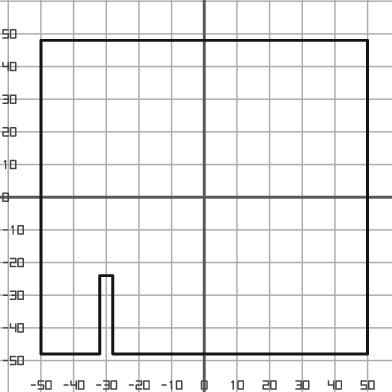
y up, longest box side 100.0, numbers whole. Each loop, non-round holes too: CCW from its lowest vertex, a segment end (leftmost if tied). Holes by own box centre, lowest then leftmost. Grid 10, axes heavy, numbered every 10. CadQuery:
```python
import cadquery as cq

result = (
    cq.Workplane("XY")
    .moveTo(-50.0, -48.0)
    .lineTo(-32.0, -48.0)
    .lineTo(-32.0, -24.0)
    .lineTo(-28.0, -24.0)
    .lineTo(-28.0, -48.0)
    .lineTo(50.0, -48.0)
    .lineTo(50.0, 48.0)
    .lineTo(-50.0, 48.0)
    .close()
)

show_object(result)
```